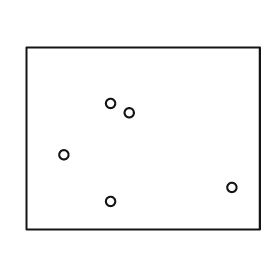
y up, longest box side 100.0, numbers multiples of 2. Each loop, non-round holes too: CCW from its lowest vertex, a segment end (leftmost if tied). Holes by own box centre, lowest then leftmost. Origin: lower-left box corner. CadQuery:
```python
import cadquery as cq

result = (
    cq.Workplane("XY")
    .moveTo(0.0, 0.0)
    .lineTo(100.0, 0.0)
    .lineTo(100.0, 78.0)
    .lineTo(0.0, 78.0)
    .close()
    .moveTo(36.0, 12.0)
    .circle(2.0)
    .moveTo(88.0, 18.0)
    .circle(2.0)
    .moveTo(16.0, 32.0)
    .circle(2.0)
    .moveTo(44.0, 50.0)
    .circle(2.0)
    .moveTo(36.0, 54.0)
    .circle(2.0)
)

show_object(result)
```